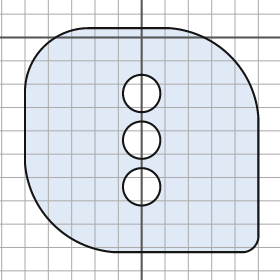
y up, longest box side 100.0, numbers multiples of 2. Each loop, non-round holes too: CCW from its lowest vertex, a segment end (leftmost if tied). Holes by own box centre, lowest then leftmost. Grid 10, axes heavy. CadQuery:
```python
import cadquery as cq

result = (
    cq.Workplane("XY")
    .moveTo(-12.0, -92.0)
    .lineTo(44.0, -92.0)
    .threePointArc((48.0, -90.0), (50.0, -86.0))
    .lineTo(50.0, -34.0)
    .threePointArc((38.0, -8.0), (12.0, 4.0))
    .lineTo(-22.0, 4.0)
    .threePointArc((-42.0, -4.0), (-50.0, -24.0))
    .lineTo(-50.0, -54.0)
    .threePointArc((-38.0, -80.0), (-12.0, -92.0))
    .close()
    .moveTo(0.0, -64.0)
    .circle(8.0)
    .moveTo(0.0, -44.0)
    .circle(8.0)
    .moveTo(0.0, -24.0)
    .circle(8.0)
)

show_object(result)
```